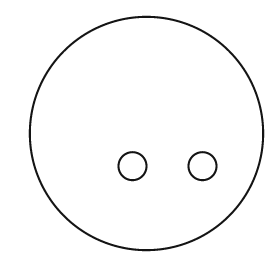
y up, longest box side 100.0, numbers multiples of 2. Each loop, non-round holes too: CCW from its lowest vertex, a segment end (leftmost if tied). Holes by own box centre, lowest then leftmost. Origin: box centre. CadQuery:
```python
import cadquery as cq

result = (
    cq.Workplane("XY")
    .moveTo(0.0, 0.0)
    .circle(50.0)
    .moveTo(-6.0, -14.0)
    .circle(6.0)
    .moveTo(24.0, -14.0)
    .circle(6.0)
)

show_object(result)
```